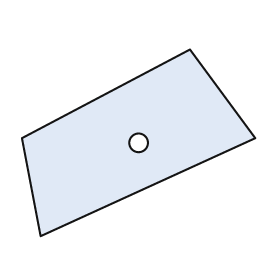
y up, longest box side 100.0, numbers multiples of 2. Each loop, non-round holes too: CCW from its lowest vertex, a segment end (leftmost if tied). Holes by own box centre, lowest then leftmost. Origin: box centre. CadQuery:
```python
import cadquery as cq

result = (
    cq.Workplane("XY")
    .moveTo(-42.0, -40.0)
    .lineTo(50.0, 2.0)
    .lineTo(22.0, 40.0)
    .lineTo(-50.0, 2.0)
    .close()
    .moveTo(0.0, 0.0)
    .circle(4.0)
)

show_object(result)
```